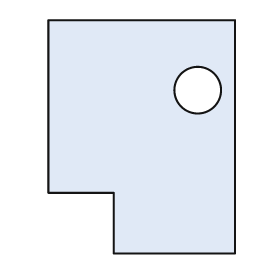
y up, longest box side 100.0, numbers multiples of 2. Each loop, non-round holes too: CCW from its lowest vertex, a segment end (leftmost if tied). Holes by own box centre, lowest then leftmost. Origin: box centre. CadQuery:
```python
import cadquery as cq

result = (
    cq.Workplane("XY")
    .moveTo(-12.0, -50.0)
    .lineTo(40.0, -50.0)
    .lineTo(40.0, 50.0)
    .lineTo(-40.0, 50.0)
    .lineTo(-40.0, -24.0)
    .lineTo(-12.0, -24.0)
    .close()
    .moveTo(24.0, 20.0)
    .circle(10.0)
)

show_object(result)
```